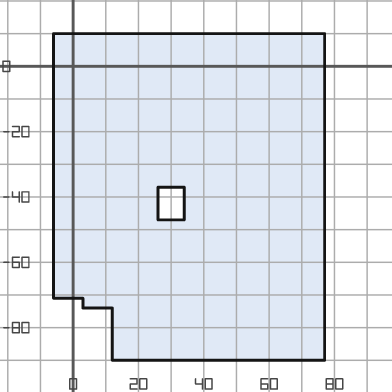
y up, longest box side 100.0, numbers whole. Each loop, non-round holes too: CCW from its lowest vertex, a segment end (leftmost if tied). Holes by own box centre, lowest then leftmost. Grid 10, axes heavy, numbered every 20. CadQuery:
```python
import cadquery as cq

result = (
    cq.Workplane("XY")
    .moveTo(12.0, -90.0)
    .lineTo(77.0, -90.0)
    .lineTo(77.0, 10.0)
    .lineTo(-6.0, 10.0)
    .lineTo(-6.0, -71.0)
    .lineTo(3.0, -71.0)
    .lineTo(3.0, -74.0)
    .lineTo(12.0, -74.0)
    .close()
    .moveTo(26.0, -47.0)
    .lineTo(34.0, -47.0)
    .lineTo(34.0, -37.0)
    .lineTo(26.0, -37.0)
    .close()
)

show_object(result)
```